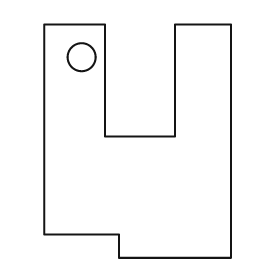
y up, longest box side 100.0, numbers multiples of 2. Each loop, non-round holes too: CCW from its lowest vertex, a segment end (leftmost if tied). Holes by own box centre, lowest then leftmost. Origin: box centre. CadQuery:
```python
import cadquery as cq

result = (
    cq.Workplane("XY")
    .moveTo(-8.0, -50.0)
    .lineTo(40.0, -50.0)
    .lineTo(40.0, 50.0)
    .lineTo(16.0, 50.0)
    .lineTo(16.0, 2.0)
    .lineTo(-14.0, 2.0)
    .lineTo(-14.0, 50.0)
    .lineTo(-40.0, 50.0)
    .lineTo(-40.0, -40.0)
    .lineTo(-8.0, -40.0)
    .close()
    .moveTo(-24.0, 36.0)
    .circle(6.0)
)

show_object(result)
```